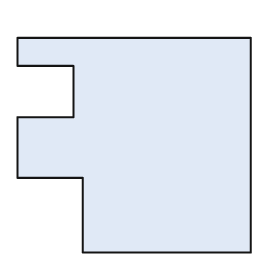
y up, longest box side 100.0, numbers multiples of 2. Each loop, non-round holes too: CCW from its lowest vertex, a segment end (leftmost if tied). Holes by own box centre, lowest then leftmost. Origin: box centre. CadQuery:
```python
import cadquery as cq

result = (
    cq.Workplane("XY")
    .moveTo(-22.0, -46.0)
    .lineTo(50.0, -46.0)
    .lineTo(50.0, 46.0)
    .lineTo(-50.0, 46.0)
    .lineTo(-50.0, 34.0)
    .lineTo(-26.0, 34.0)
    .lineTo(-26.0, 12.0)
    .lineTo(-50.0, 12.0)
    .lineTo(-50.0, -14.0)
    .lineTo(-22.0, -14.0)
    .close()
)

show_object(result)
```